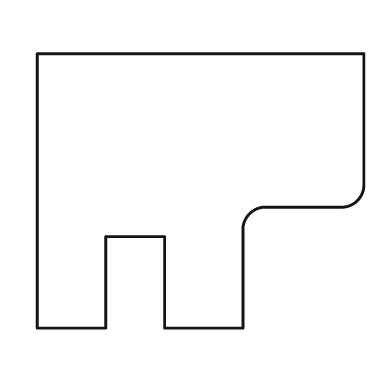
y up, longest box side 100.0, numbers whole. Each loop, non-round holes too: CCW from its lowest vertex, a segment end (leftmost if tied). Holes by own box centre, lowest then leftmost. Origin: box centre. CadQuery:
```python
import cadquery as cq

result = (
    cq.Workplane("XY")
    .moveTo(-50.0, -42.0)
    .lineTo(-29.0, -42.0)
    .lineTo(-29.0, -14.0)
    .lineTo(-11.0, -14.0)
    .lineTo(-11.0, -42.0)
    .lineTo(13.0, -42.0)
    .lineTo(13.0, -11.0)
    .threePointArc((15.0, -7.0), (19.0, -5.0))
    .lineTo(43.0, -5.0)
    .threePointArc((48.0, -3.0), (50.0, 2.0))
    .lineTo(50.0, 42.0)
    .lineTo(-50.0, 42.0)
    .close()
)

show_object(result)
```